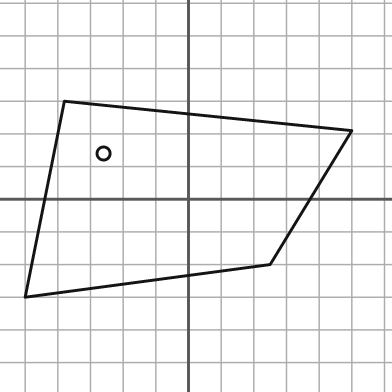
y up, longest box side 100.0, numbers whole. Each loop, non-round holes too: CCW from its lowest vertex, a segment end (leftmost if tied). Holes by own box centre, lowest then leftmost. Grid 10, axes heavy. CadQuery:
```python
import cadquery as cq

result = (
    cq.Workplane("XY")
    .moveTo(-50.0, -30.0)
    .lineTo(25.0, -20.0)
    .lineTo(50.0, 21.0)
    .lineTo(-38.0, 30.0)
    .close()
    .moveTo(-26.0, 14.0)
    .circle(2.0)
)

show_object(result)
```